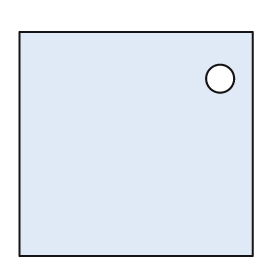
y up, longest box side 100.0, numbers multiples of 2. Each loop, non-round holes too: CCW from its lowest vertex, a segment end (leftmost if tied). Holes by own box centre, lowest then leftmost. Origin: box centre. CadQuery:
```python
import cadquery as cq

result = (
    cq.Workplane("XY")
    .moveTo(-50.0, -48.0)
    .lineTo(50.0, -48.0)
    .lineTo(50.0, 48.0)
    .lineTo(-50.0, 48.0)
    .close()
    .moveTo(36.0, 28.0)
    .circle(6.0)
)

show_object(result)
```